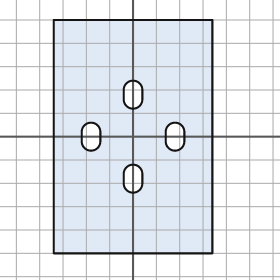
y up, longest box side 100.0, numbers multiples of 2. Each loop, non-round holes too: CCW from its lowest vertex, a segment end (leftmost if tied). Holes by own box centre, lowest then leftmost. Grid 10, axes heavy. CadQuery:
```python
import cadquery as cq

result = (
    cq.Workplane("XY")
    .moveTo(-34.0, -50.0)
    .lineTo(34.0, -50.0)
    .lineTo(34.0, 50.0)
    .lineTo(-34.0, 50.0)
    .close()
    .moveTo(-4.0, -20.0)
    .threePointArc((0.0, -24.0), (4.0, -20.0))
    .lineTo(4.0, -16.0)
    .threePointArc((0.0, -12.0), (-4.0, -16.0))
    .close()
    .moveTo(-22.0, -2.0)
    .threePointArc((-18.0, -6.0), (-14.0, -2.0))
    .lineTo(-14.0, 2.0)
    .threePointArc((-18.0, 6.0), (-22.0, 2.0))
    .close()
    .moveTo(14.0, -2.0)
    .threePointArc((18.0, -6.0), (22.0, -2.0))
    .lineTo(22.0, 2.0)
    .threePointArc((18.0, 6.0), (14.0, 2.0))
    .close()
    .moveTo(-4.0, 16.0)
    .threePointArc((0.0, 12.0), (4.0, 16.0))
    .lineTo(4.0, 20.0)
    .threePointArc((0.0, 24.0), (-4.0, 20.0))
    .close()
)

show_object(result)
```